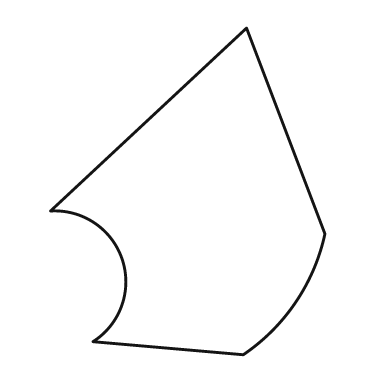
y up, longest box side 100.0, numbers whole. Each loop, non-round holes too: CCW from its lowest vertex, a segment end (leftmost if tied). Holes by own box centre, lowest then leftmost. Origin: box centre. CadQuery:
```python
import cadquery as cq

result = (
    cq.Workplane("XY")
    .moveTo(17.0, -50.0)
    .threePointArc((33.0, -34.0), (42.0, -13.0))
    .lineTo(18.0, 50.0)
    .lineTo(-42.0, -6.0)
    .threePointArc((-20.0, -21.0), (-29.0, -46.0))
    .close()
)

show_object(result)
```